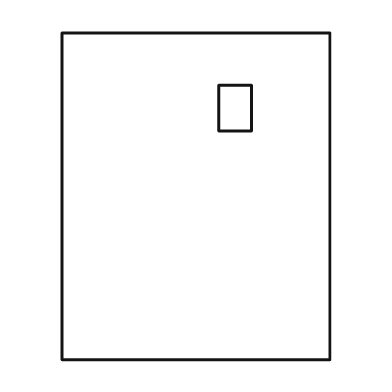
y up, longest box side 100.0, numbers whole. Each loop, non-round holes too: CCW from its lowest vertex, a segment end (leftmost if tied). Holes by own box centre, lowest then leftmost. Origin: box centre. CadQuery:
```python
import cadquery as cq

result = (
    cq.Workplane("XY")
    .moveTo(-41.0, -50.0)
    .lineTo(41.0, -50.0)
    .lineTo(41.0, 50.0)
    .lineTo(-41.0, 50.0)
    .close()
    .moveTo(7.0, 20.0)
    .lineTo(17.0, 20.0)
    .lineTo(17.0, 34.0)
    .lineTo(7.0, 34.0)
    .close()
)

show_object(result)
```